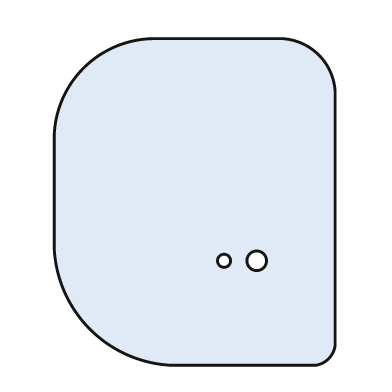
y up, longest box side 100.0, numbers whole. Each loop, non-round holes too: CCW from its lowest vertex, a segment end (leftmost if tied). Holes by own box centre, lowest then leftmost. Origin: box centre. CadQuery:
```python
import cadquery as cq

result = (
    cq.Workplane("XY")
    .moveTo(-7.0, -50.0)
    .lineTo(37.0, -50.0)
    .threePointArc((41.0, -48.0), (43.0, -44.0))
    .lineTo(43.0, 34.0)
    .threePointArc((38.0, 45.0), (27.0, 50.0))
    .lineTo(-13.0, 50.0)
    .threePointArc((-34.0, 41.0), (-43.0, 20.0))
    .lineTo(-43.0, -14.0)
    .threePointArc((-32.0, -39.0), (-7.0, -50.0))
    .close()
    .moveTo(9.0, -18.0)
    .circle(2.0)
    .moveTo(19.0, -18.0)
    .circle(3.0)
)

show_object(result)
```